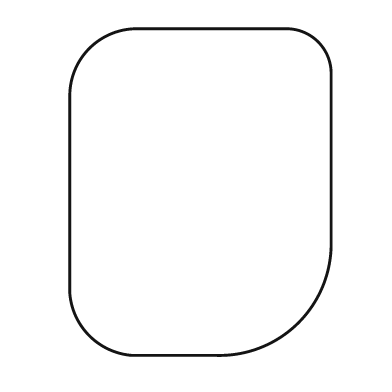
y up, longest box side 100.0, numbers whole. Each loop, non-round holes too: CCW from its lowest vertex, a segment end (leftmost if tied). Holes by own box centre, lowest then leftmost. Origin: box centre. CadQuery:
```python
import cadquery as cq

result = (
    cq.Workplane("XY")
    .moveTo(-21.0, -50.0)
    .lineTo(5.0, -50.0)
    .threePointArc((30.0, -40.0), (40.0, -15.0))
    .lineTo(40.0, 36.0)
    .threePointArc((36.0, 46.0), (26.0, 50.0))
    .lineTo(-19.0, 50.0)
    .threePointArc((-34.0, 44.0), (-40.0, 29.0))
    .lineTo(-40.0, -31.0)
    .threePointArc((-34.0, -44.0), (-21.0, -50.0))
    .close()
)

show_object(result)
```